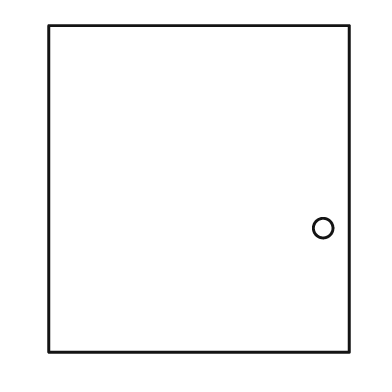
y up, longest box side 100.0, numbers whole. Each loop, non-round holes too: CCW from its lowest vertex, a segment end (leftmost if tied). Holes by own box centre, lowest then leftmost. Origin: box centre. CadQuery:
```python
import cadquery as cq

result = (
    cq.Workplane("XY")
    .moveTo(-46.0, -50.0)
    .lineTo(46.0, -50.0)
    .lineTo(46.0, 50.0)
    .lineTo(-46.0, 50.0)
    .close()
    .moveTo(38.0, -12.0)
    .circle(3.0)
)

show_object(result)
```